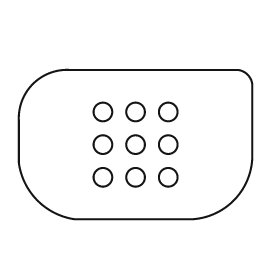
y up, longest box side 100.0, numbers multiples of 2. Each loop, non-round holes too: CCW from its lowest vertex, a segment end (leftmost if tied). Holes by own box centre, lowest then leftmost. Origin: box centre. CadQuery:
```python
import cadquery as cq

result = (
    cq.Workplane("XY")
    .moveTo(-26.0, -32.0)
    .lineTo(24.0, -32.0)
    .threePointArc((42.0, -24.0), (50.0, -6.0))
    .lineTo(50.0, 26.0)
    .threePointArc((48.0, 30.0), (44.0, 32.0))
    .lineTo(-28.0, 32.0)
    .threePointArc((-44.0, 26.0), (-50.0, 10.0))
    .lineTo(-50.0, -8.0)
    .threePointArc((-42.0, -24.0), (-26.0, -32.0))
    .close()
    .moveTo(-14.0, -14.0)
    .circle(4.0)
    .moveTo(0.0, -14.0)
    .circle(4.0)
    .moveTo(14.0, -14.0)
    .circle(4.0)
    .moveTo(-14.0, 0.0)
    .circle(4.0)
    .moveTo(0.0, 0.0)
    .circle(4.0)
    .moveTo(14.0, 0.0)
    .circle(4.0)
    .moveTo(-14.0, 14.0)
    .circle(4.0)
    .moveTo(0.0, 14.0)
    .circle(4.0)
    .moveTo(14.0, 14.0)
    .circle(4.0)
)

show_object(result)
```